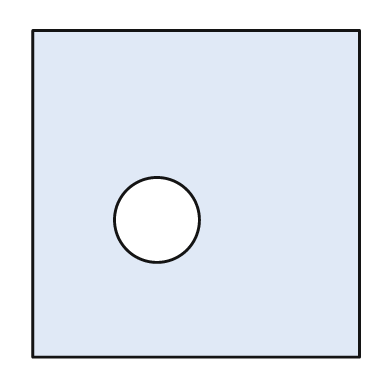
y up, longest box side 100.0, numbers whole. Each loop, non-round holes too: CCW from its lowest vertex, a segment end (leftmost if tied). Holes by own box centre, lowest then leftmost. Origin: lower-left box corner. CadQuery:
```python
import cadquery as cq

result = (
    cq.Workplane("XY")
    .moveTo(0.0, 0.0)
    .lineTo(100.0, 0.0)
    .lineTo(100.0, 100.0)
    .lineTo(0.0, 100.0)
    .close()
    .moveTo(38.0, 42.0)
    .circle(13.0)
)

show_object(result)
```